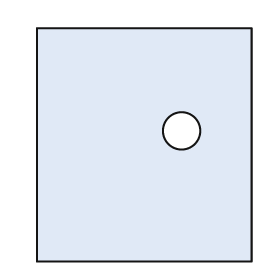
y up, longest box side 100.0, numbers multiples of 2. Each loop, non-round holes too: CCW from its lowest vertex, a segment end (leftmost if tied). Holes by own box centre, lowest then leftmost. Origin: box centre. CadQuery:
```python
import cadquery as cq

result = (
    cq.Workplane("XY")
    .moveTo(-46.0, -50.0)
    .lineTo(46.0, -50.0)
    .lineTo(46.0, 50.0)
    .lineTo(-46.0, 50.0)
    .close()
    .moveTo(16.0, 6.0)
    .circle(8.0)
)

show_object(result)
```